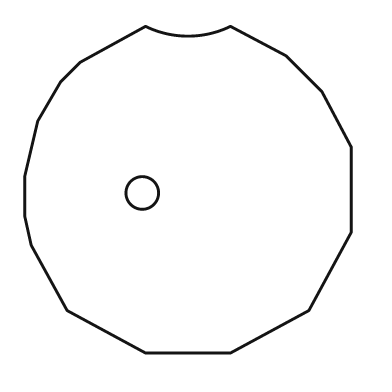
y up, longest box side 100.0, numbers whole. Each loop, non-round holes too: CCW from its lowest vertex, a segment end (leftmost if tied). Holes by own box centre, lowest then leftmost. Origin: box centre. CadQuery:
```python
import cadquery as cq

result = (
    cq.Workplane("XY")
    .moveTo(-13.0, -50.0)
    .lineTo(13.0, -50.0)
    .lineTo(37.0, -37.0)
    .lineTo(50.0, -13.0)
    .lineTo(50.0, 13.0)
    .lineTo(41.0, 30.0)
    .lineTo(30.0, 41.0)
    .lineTo(13.0, 50.0)
    .threePointArc((0.0, 47.0), (-13.0, 50.0))
    .lineTo(-33.0, 39.0)
    .lineTo(-39.0, 33.0)
    .lineTo(-46.0, 21.0)
    .lineTo(-50.0, 4.0)
    .lineTo(-50.0, -8.0)
    .lineTo(-48.0, -17.0)
    .lineTo(-37.0, -37.0)
    .close()
    .moveTo(-14.0, -1.0)
    .circle(5.0)
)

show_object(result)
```